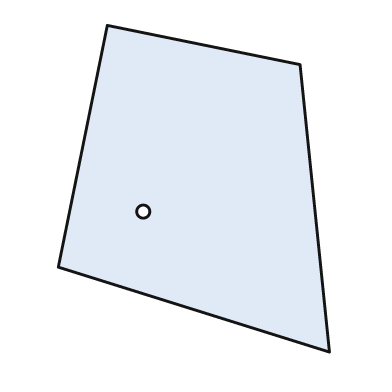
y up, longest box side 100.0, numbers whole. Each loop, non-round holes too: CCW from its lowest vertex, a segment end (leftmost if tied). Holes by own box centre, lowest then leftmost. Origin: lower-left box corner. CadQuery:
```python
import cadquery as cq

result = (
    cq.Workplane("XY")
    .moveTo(83.0, 0.0)
    .lineTo(74.0, 88.0)
    .lineTo(15.0, 100.0)
    .lineTo(0.0, 26.0)
    .close()
    .moveTo(26.0, 43.0)
    .circle(2.0)
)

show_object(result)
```